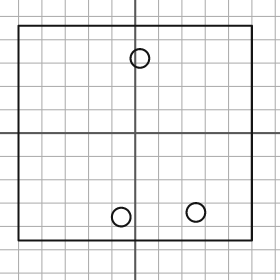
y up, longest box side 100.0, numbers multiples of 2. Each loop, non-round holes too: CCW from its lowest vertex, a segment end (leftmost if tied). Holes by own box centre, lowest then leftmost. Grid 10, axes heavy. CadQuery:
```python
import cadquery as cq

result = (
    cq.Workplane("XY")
    .moveTo(-50.0, -46.0)
    .lineTo(50.0, -46.0)
    .lineTo(50.0, 46.0)
    .lineTo(-50.0, 46.0)
    .close()
    .moveTo(-6.0, -36.0)
    .circle(4.0)
    .moveTo(26.0, -34.0)
    .circle(4.0)
    .moveTo(2.0, 32.0)
    .circle(4.0)
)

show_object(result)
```